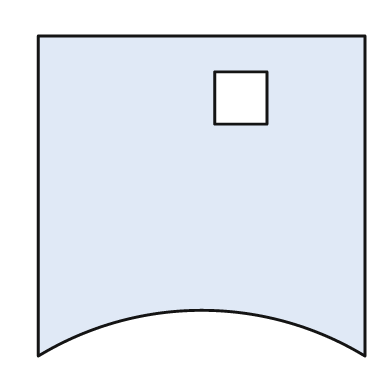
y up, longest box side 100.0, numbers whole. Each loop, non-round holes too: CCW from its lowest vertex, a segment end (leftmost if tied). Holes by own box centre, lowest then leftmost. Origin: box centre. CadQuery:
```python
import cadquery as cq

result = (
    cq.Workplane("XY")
    .moveTo(-50.0, -49.0)
    .threePointArc((0.0, -35.0), (50.0, -49.0))
    .lineTo(50.0, 49.0)
    .lineTo(-50.0, 49.0)
    .close()
    .moveTo(4.0, 22.0)
    .lineTo(20.0, 22.0)
    .lineTo(20.0, 38.0)
    .lineTo(4.0, 38.0)
    .close()
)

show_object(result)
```